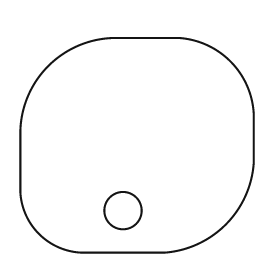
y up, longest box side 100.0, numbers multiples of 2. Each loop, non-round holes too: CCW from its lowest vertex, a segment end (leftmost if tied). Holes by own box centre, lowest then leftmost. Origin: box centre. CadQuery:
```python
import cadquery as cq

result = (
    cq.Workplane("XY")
    .moveTo(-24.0, -46.0)
    .lineTo(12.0, -46.0)
    .threePointArc((38.0, -34.0), (50.0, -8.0))
    .lineTo(50.0, 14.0)
    .threePointArc((40.0, 36.0), (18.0, 46.0))
    .lineTo(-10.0, 46.0)
    .threePointArc((-38.0, 34.0), (-50.0, 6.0))
    .lineTo(-50.0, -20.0)
    .threePointArc((-42.0, -38.0), (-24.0, -46.0))
    .close()
    .moveTo(-6.0, -28.0)
    .circle(8.0)
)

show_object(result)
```